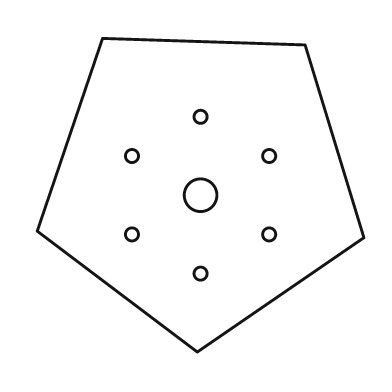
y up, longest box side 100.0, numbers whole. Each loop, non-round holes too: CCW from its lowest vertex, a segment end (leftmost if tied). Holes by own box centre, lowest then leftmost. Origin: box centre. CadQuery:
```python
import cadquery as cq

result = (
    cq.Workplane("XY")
    .moveTo(-1.0, -48.0)
    .lineTo(50.0, -13.0)
    .lineTo(32.0, 46.0)
    .lineTo(-30.0, 48.0)
    .lineTo(-50.0, -11.0)
    .close()
    .moveTo(0.0, -24.0)
    .circle(2.0)
    .moveTo(-21.0, -12.0)
    .circle(2.0)
    .moveTo(21.0, -12.0)
    .circle(2.0)
    .moveTo(0.0, 0.0)
    .circle(5.0)
    .moveTo(-21.0, 12.0)
    .circle(2.0)
    .moveTo(21.0, 12.0)
    .circle(2.0)
    .moveTo(0.0, 24.0)
    .circle(2.0)
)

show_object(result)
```